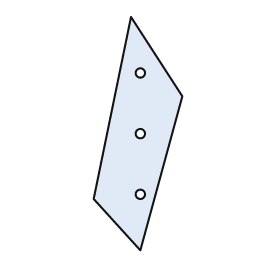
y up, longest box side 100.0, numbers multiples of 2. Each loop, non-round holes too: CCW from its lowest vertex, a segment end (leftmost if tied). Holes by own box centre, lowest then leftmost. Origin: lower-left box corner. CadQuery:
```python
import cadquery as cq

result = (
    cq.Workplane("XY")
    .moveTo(20.0, 0.0)
    .lineTo(38.0, 66.0)
    .lineTo(16.0, 100.0)
    .lineTo(0.0, 22.0)
    .close()
    .moveTo(20.0, 24.0)
    .circle(2.0)
    .moveTo(20.0, 50.0)
    .circle(2.0)
    .moveTo(20.0, 76.0)
    .circle(2.0)
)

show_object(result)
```